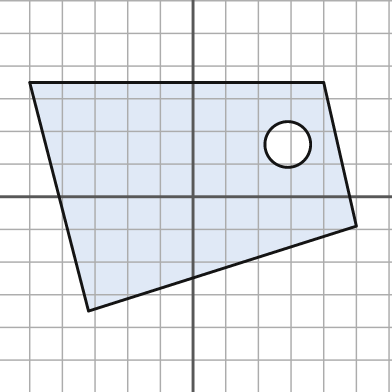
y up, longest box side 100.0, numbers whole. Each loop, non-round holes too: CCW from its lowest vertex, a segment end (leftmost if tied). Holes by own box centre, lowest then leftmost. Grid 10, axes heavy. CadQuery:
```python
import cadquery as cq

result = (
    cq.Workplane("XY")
    .moveTo(-32.0, -35.0)
    .lineTo(50.0, -9.0)
    .lineTo(40.0, 35.0)
    .lineTo(-50.0, 35.0)
    .close()
    .moveTo(29.0, 16.0)
    .circle(7.0)
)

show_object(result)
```